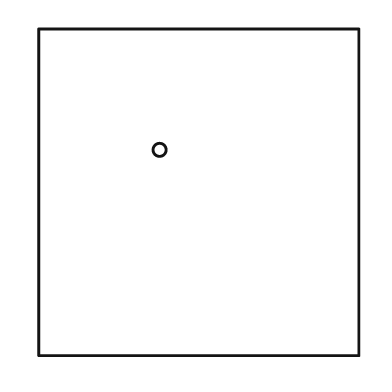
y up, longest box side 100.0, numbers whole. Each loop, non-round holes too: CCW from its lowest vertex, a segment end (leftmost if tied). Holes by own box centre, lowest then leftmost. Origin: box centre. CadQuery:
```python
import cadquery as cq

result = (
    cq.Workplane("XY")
    .moveTo(-49.0, -50.0)
    .lineTo(49.0, -50.0)
    .lineTo(49.0, 50.0)
    .lineTo(-49.0, 50.0)
    .close()
    .moveTo(-12.0, 13.0)
    .circle(2.0)
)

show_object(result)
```